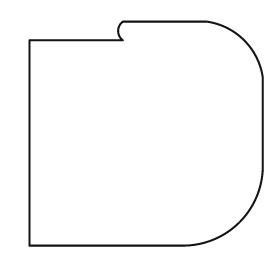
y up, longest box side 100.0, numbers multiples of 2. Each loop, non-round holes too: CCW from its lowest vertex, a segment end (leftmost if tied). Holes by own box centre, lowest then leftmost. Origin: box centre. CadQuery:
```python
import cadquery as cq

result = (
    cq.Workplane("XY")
    .moveTo(-50.0, -48.0)
    .lineTo(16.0, -48.0)
    .threePointArc((40.0, -38.0), (50.0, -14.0))
    .lineTo(50.0, 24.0)
    .threePointArc((42.0, 40.0), (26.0, 48.0))
    .lineTo(-10.0, 48.0)
    .threePointArc((-12.0, 44.0), (-10.0, 40.0))
    .lineTo(-50.0, 40.0)
    .close()
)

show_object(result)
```